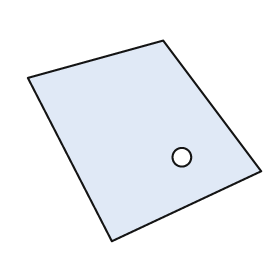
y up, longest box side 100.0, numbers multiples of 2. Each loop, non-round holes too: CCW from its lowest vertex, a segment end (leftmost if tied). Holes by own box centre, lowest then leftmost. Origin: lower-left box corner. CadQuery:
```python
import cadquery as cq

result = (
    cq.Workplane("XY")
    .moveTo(36.0, 0.0)
    .lineTo(100.0, 30.0)
    .lineTo(58.0, 86.0)
    .lineTo(0.0, 70.0)
    .close()
    .moveTo(66.0, 36.0)
    .circle(4.0)
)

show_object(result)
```